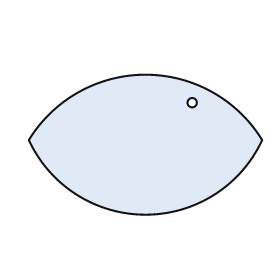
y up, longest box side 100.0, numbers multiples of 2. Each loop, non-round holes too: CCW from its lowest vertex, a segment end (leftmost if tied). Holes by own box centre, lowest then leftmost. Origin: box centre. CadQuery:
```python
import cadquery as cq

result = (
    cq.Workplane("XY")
    .moveTo(-50.0, 2.0)
    .threePointArc((0.0, -30.0), (50.0, 2.0))
    .threePointArc((0.0, 30.0), (-50.0, 2.0))
    .close()
    .moveTo(20.0, 18.0)
    .circle(2.0)
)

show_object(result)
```